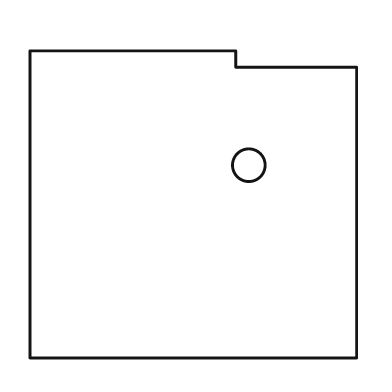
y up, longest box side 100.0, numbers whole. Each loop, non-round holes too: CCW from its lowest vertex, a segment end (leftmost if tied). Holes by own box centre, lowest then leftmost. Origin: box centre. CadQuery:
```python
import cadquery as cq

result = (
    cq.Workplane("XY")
    .moveTo(-50.0, -47.0)
    .lineTo(50.0, -47.0)
    .lineTo(50.0, 42.0)
    .lineTo(13.0, 42.0)
    .lineTo(13.0, 47.0)
    .lineTo(-50.0, 47.0)
    .close()
    .moveTo(17.0, 12.0)
    .circle(5.0)
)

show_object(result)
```